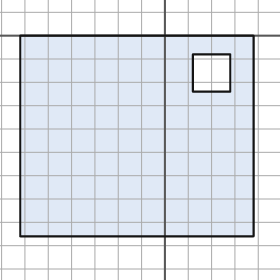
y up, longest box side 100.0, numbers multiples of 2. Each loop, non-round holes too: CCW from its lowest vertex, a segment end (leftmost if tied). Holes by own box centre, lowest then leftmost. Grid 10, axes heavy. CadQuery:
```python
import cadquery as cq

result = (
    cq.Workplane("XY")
    .moveTo(-62.0, -86.0)
    .lineTo(38.0, -86.0)
    .lineTo(38.0, 0.0)
    .lineTo(-62.0, 0.0)
    .close()
    .moveTo(12.0, -24.0)
    .lineTo(28.0, -24.0)
    .lineTo(28.0, -8.0)
    .lineTo(12.0, -8.0)
    .close()
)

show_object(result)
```